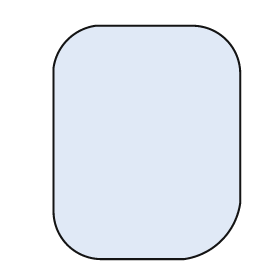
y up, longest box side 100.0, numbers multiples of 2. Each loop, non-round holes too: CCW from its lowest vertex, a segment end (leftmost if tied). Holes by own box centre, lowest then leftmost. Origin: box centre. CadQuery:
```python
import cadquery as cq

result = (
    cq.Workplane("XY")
    .moveTo(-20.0, -50.0)
    .lineTo(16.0, -50.0)
    .threePointArc((32.0, -42.0), (40.0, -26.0))
    .lineTo(40.0, 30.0)
    .threePointArc((34.0, 44.0), (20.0, 50.0))
    .lineTo(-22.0, 50.0)
    .threePointArc((-34.0, 44.0), (-40.0, 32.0))
    .lineTo(-40.0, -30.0)
    .threePointArc((-34.0, -44.0), (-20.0, -50.0))
    .close()
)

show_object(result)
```